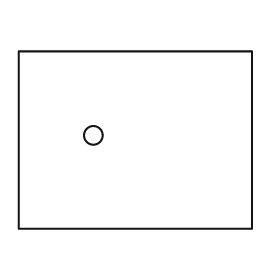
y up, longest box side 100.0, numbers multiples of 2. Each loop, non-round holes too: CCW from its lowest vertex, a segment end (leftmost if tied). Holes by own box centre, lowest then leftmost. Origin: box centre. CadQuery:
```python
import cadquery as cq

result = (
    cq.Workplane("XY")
    .moveTo(-50.0, -38.0)
    .lineTo(50.0, -38.0)
    .lineTo(50.0, 38.0)
    .lineTo(-50.0, 38.0)
    .close()
    .moveTo(-18.0, 2.0)
    .circle(4.0)
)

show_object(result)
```